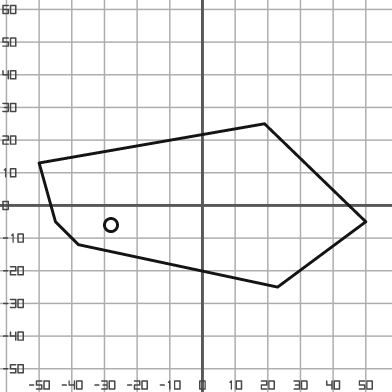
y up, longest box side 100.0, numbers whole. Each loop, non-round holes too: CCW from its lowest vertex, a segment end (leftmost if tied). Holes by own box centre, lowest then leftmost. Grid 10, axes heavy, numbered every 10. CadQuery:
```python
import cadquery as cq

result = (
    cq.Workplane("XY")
    .moveTo(23.0, -25.0)
    .lineTo(50.0, -5.0)
    .lineTo(19.0, 25.0)
    .lineTo(-50.0, 13.0)
    .lineTo(-45.0, -5.0)
    .lineTo(-38.0, -12.0)
    .close()
    .moveTo(-28.0, -6.0)
    .circle(2.0)
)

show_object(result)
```